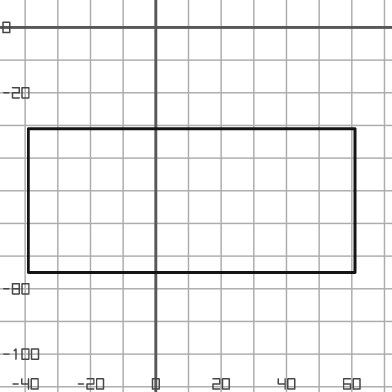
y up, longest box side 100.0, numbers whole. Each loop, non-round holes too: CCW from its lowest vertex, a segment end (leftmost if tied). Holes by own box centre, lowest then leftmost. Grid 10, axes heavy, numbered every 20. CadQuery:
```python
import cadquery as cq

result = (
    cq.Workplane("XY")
    .moveTo(-39.0, -75.0)
    .lineTo(61.0, -75.0)
    .lineTo(61.0, -31.0)
    .lineTo(-39.0, -31.0)
    .close()
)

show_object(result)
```